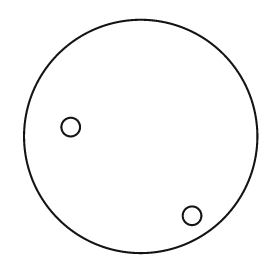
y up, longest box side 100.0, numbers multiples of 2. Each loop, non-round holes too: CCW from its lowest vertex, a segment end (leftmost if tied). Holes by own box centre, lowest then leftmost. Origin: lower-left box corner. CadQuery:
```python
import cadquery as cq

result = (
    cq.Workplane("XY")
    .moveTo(50.0, 50.0)
    .circle(50.0)
    .moveTo(72.0, 16.0)
    .circle(4.0)
    .moveTo(20.0, 54.0)
    .circle(4.0)
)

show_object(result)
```